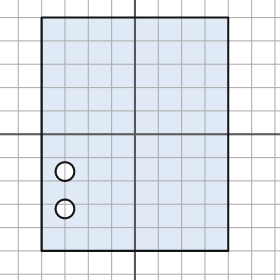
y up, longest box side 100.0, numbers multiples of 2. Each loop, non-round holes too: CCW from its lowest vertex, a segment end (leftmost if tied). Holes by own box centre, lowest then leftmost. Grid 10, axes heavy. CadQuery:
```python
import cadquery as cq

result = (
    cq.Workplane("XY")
    .moveTo(-40.0, -50.0)
    .lineTo(40.0, -50.0)
    .lineTo(40.0, 50.0)
    .lineTo(-40.0, 50.0)
    .close()
    .moveTo(-30.0, -32.0)
    .circle(4.0)
    .moveTo(-30.0, -16.0)
    .circle(4.0)
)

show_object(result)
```